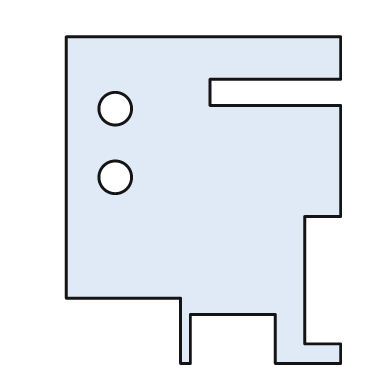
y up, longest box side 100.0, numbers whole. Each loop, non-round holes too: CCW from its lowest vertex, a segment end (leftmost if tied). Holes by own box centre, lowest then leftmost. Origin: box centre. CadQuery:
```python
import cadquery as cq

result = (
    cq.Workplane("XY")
    .moveTo(-7.0, -50.0)
    .lineTo(-4.0, -50.0)
    .lineTo(-4.0, -35.0)
    .lineTo(22.0, -35.0)
    .lineTo(22.0, -50.0)
    .lineTo(42.0, -50.0)
    .lineTo(42.0, -44.0)
    .lineTo(31.0, -44.0)
    .lineTo(31.0, -5.0)
    .lineTo(42.0, -5.0)
    .lineTo(42.0, 29.0)
    .lineTo(2.0, 29.0)
    .lineTo(2.0, 37.0)
    .lineTo(42.0, 37.0)
    .lineTo(42.0, 50.0)
    .lineTo(-42.0, 50.0)
    .lineTo(-42.0, -30.0)
    .lineTo(-7.0, -30.0)
    .close()
    .moveTo(-27.0, 7.0)
    .circle(5.0)
    .moveTo(-27.0, 28.0)
    .circle(5.0)
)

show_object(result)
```